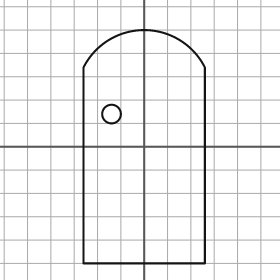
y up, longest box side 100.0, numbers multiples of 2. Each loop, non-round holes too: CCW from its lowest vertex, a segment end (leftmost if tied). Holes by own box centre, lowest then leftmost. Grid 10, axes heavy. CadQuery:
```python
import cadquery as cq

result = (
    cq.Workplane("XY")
    .moveTo(-26.0, -50.0)
    .lineTo(26.0, -50.0)
    .lineTo(26.0, 34.0)
    .threePointArc((0.0, 50.0), (-26.0, 34.0))
    .close()
    .moveTo(-14.0, 14.0)
    .circle(4.0)
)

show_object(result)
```